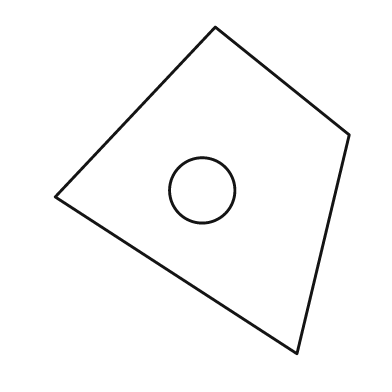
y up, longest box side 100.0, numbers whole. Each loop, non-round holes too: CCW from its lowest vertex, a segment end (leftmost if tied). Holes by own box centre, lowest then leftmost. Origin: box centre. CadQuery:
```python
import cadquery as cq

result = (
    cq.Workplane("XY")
    .moveTo(29.0, -50.0)
    .lineTo(45.0, 17.0)
    .lineTo(4.0, 50.0)
    .lineTo(-45.0, -2.0)
    .close()
    .moveTo(0.0, 0.0)
    .circle(10.0)
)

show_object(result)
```